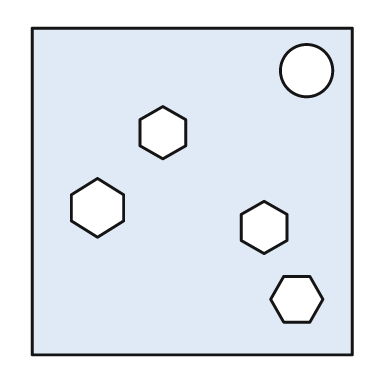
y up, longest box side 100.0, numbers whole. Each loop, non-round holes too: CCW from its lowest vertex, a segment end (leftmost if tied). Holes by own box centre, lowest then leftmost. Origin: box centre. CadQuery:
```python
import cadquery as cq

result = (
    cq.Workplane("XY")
    .moveTo(-49.0, -50.0)
    .lineTo(49.0, -50.0)
    .lineTo(49.0, 50.0)
    .lineTo(-49.0, 50.0)
    .close()
    .moveTo(28.0, -40.0)
    .lineTo(36.0, -40.0)
    .lineTo(40.0, -33.0)
    .lineTo(36.0, -26.0)
    .lineTo(28.0, -26.0)
    .lineTo(24.0, -33.0)
    .close()
    .moveTo(22.0, -19.0)
    .lineTo(29.0, -15.0)
    .lineTo(29.0, -7.0)
    .lineTo(22.0, -3.0)
    .lineTo(15.0, -7.0)
    .lineTo(15.0, -15.0)
    .close()
    .moveTo(-29.0, -14.0)
    .lineTo(-21.0, -9.0)
    .lineTo(-21.0, -1.0)
    .lineTo(-29.0, 4.0)
    .lineTo(-37.0, -1.0)
    .lineTo(-37.0, -9.0)
    .close()
    .moveTo(-9.0, 10.0)
    .lineTo(-2.0, 14.0)
    .lineTo(-2.0, 22.0)
    .lineTo(-9.0, 26.0)
    .lineTo(-16.0, 22.0)
    .lineTo(-16.0, 14.0)
    .close()
    .moveTo(35.0, 37.0)
    .circle(8.0)
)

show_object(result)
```